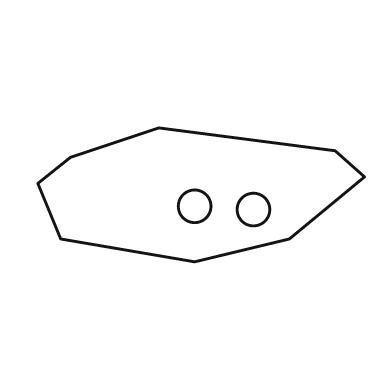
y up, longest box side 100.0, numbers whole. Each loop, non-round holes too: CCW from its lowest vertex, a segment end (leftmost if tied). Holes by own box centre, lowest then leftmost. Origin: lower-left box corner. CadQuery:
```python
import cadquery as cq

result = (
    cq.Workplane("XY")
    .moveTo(48.0, 0.0)
    .lineTo(77.0, 7.0)
    .lineTo(100.0, 26.0)
    .lineTo(91.0, 34.0)
    .lineTo(37.0, 41.0)
    .lineTo(10.0, 32.0)
    .lineTo(0.0, 24.0)
    .lineTo(7.0, 7.0)
    .close()
    .moveTo(66.0, 16.0)
    .circle(5.0)
    .moveTo(48.0, 17.0)
    .circle(5.0)
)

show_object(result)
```